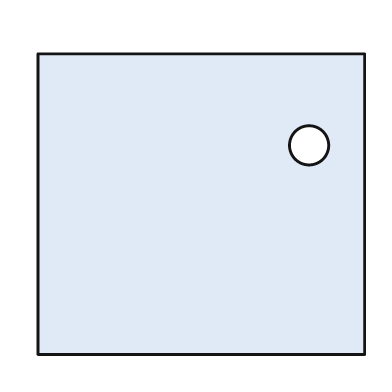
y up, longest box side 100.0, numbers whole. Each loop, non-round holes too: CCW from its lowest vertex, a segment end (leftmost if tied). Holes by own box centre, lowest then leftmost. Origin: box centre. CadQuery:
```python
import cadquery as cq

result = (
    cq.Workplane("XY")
    .moveTo(-50.0, -46.0)
    .lineTo(50.0, -46.0)
    .lineTo(50.0, 46.0)
    .lineTo(-50.0, 46.0)
    .close()
    .moveTo(33.0, 18.0)
    .circle(6.0)
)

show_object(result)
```